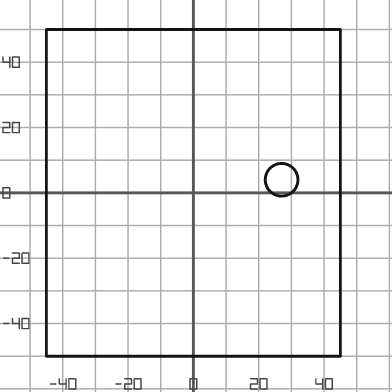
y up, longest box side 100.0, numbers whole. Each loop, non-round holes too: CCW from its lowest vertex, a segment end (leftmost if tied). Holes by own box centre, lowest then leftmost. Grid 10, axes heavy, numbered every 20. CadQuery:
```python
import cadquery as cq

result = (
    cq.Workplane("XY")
    .moveTo(-45.0, -50.0)
    .lineTo(45.0, -50.0)
    .lineTo(45.0, 50.0)
    .lineTo(-45.0, 50.0)
    .close()
    .moveTo(27.0, 4.0)
    .circle(5.0)
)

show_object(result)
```